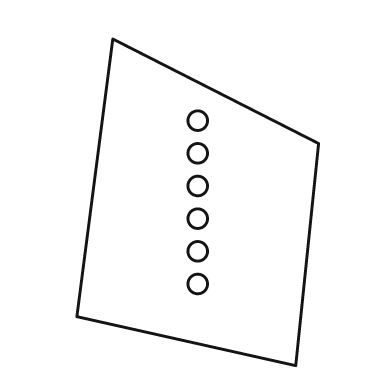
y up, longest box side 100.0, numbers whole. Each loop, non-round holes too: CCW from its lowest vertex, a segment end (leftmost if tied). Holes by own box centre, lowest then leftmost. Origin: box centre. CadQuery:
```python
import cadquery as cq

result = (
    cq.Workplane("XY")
    .moveTo(30.0, -50.0)
    .lineTo(37.0, 18.0)
    .lineTo(-26.0, 50.0)
    .lineTo(-37.0, -35.0)
    .close()
    .moveTo(0.0, -25.0)
    .circle(3.0)
    .moveTo(0.0, -15.0)
    .circle(3.0)
    .moveTo(0.0, -5.0)
    .circle(3.0)
    .moveTo(0.0, 5.0)
    .circle(3.0)
    .moveTo(0.0, 15.0)
    .circle(3.0)
    .moveTo(0.0, 25.0)
    .circle(3.0)
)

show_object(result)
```